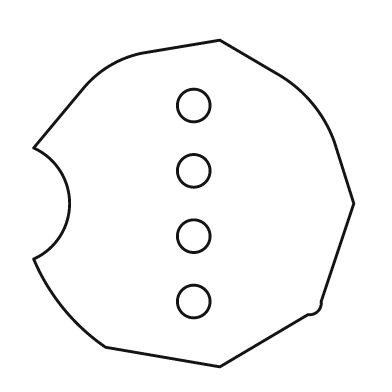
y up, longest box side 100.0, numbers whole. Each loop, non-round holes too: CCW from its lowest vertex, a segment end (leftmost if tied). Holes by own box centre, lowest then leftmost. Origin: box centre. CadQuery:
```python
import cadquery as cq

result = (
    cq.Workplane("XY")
    .moveTo(8.0, -50.0)
    .lineTo(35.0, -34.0)
    .threePointArc((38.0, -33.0), (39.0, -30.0))
    .lineTo(49.0, 0.0)
    .lineTo(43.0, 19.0)
    .threePointArc((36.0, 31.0), (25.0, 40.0))
    .lineTo(8.0, 50.0)
    .lineTo(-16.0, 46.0)
    .threePointArc((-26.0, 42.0), (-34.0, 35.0))
    .lineTo(-49.0, 17.0)
    .threePointArc((-38.0, 0.0), (-49.0, -17.0))
    .threePointArc((-40.0, -32.0), (-27.0, -44.0))
    .close()
    .moveTo(0.0, -30.0)
    .circle(5.0)
    .moveTo(0.0, -10.0)
    .circle(5.0)
    .moveTo(0.0, 10.0)
    .circle(5.0)
    .moveTo(0.0, 30.0)
    .circle(5.0)
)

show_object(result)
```